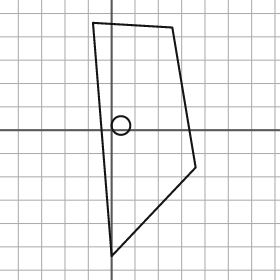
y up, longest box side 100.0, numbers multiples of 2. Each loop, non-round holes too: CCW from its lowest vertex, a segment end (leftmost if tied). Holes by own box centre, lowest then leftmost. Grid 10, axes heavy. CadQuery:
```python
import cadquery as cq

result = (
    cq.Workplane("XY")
    .moveTo(0.0, -54.0)
    .lineTo(36.0, -16.0)
    .lineTo(26.0, 44.0)
    .lineTo(-8.0, 46.0)
    .close()
    .moveTo(4.0, 2.0)
    .circle(4.0)
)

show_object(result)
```